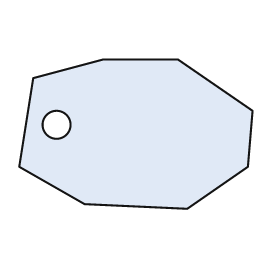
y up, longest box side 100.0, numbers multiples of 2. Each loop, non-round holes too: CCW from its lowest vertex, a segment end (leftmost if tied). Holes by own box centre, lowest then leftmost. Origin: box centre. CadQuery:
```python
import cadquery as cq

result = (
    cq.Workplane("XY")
    .moveTo(22.0, -32.0)
    .lineTo(48.0, -14.0)
    .lineTo(50.0, 10.0)
    .lineTo(18.0, 32.0)
    .lineTo(-14.0, 32.0)
    .lineTo(-44.0, 24.0)
    .lineTo(-50.0, -14.0)
    .lineTo(-22.0, -30.0)
    .close()
    .moveTo(-34.0, 4.0)
    .circle(6.0)
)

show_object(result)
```